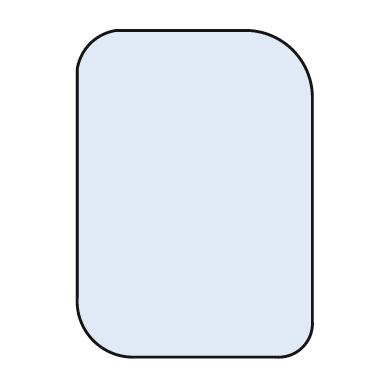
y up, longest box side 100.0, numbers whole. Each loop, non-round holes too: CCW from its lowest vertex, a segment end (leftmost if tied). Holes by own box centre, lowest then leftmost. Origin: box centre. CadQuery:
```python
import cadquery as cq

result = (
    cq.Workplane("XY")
    .moveTo(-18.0, -50.0)
    .lineTo(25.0, -50.0)
    .threePointArc((33.0, -47.0), (36.0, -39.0))
    .lineTo(36.0, 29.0)
    .threePointArc((30.0, 44.0), (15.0, 50.0))
    .lineTo(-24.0, 50.0)
    .threePointArc((-32.0, 46.0), (-36.0, 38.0))
    .lineTo(-36.0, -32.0)
    .threePointArc((-31.0, -45.0), (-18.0, -50.0))
    .close()
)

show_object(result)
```